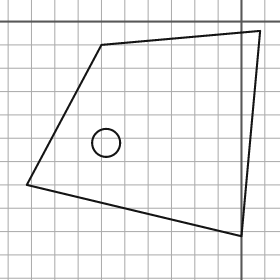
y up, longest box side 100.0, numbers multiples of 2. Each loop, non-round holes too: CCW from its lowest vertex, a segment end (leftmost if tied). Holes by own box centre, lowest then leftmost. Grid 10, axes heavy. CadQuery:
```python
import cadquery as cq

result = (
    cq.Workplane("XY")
    .moveTo(0.0, -92.0)
    .lineTo(8.0, -4.0)
    .lineTo(-60.0, -10.0)
    .lineTo(-92.0, -70.0)
    .close()
    .moveTo(-58.0, -52.0)
    .circle(6.0)
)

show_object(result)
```